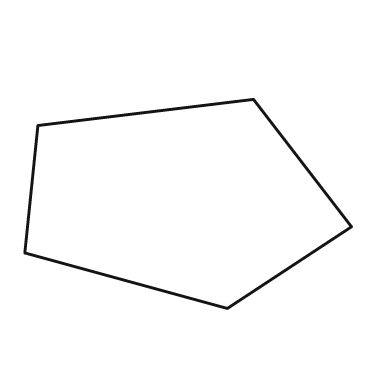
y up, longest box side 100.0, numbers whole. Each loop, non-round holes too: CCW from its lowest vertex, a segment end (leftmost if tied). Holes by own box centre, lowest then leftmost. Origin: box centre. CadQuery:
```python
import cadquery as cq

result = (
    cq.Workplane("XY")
    .moveTo(12.0, -32.0)
    .lineTo(50.0, -7.0)
    .lineTo(20.0, 32.0)
    .lineTo(-46.0, 24.0)
    .lineTo(-50.0, -15.0)
    .close()
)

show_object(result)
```